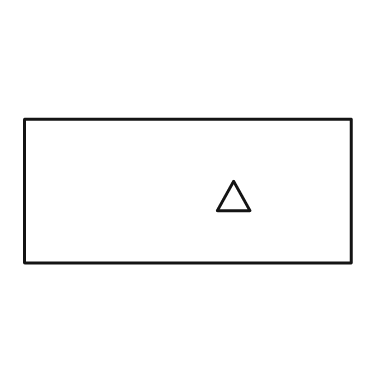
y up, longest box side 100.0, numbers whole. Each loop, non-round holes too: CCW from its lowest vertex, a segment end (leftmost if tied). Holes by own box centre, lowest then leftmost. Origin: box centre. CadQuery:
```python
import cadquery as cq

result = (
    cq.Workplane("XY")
    .moveTo(-50.0, -22.0)
    .lineTo(50.0, -22.0)
    .lineTo(50.0, 22.0)
    .lineTo(-50.0, 22.0)
    .close()
    .moveTo(9.0, -6.0)
    .lineTo(19.0, -6.0)
    .lineTo(14.0, 3.0)
    .close()
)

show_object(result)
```